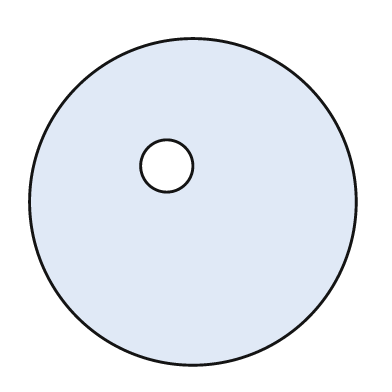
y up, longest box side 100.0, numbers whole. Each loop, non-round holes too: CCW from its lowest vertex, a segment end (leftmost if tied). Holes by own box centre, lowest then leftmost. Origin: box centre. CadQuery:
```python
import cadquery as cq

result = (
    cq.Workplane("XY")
    .moveTo(0.0, 0.0)
    .circle(50.0)
    .moveTo(-8.0, 11.0)
    .circle(8.0)
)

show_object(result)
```